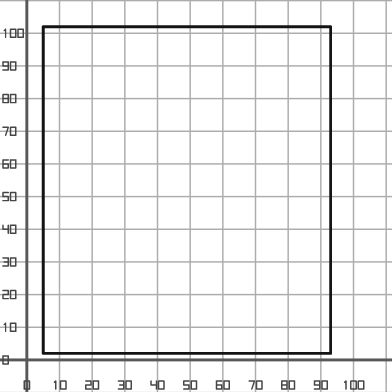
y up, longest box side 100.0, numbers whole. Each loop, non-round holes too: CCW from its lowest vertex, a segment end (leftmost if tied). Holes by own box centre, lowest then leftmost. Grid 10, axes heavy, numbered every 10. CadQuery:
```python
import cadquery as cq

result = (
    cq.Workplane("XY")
    .moveTo(5.0, 2.0)
    .lineTo(93.0, 2.0)
    .lineTo(93.0, 102.0)
    .lineTo(5.0, 102.0)
    .close()
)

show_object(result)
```